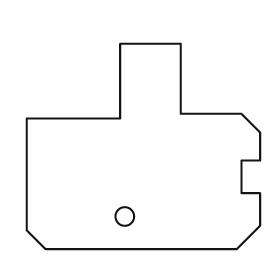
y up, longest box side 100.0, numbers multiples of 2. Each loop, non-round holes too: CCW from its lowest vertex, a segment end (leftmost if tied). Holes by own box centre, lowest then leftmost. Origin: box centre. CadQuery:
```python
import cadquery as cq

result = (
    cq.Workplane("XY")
    .moveTo(-42.0, -44.0)
    .lineTo(40.0, -44.0)
    .lineTo(50.0, -34.0)
    .lineTo(50.0, -20.0)
    .lineTo(42.0, -20.0)
    .lineTo(42.0, -6.0)
    .lineTo(50.0, -6.0)
    .lineTo(50.0, 6.0)
    .lineTo(42.0, 14.0)
    .lineTo(16.0, 14.0)
    .lineTo(16.0, 44.0)
    .lineTo(-10.0, 44.0)
    .lineTo(-10.0, 12.0)
    .lineTo(-50.0, 12.0)
    .lineTo(-50.0, -36.0)
    .close()
    .moveTo(-8.0, -30.0)
    .circle(4.0)
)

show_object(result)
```